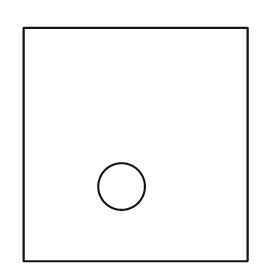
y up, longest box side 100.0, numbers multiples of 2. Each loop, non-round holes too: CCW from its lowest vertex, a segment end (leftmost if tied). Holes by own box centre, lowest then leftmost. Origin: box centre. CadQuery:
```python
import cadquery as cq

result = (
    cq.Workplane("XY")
    .moveTo(-48.0, -50.0)
    .lineTo(48.0, -50.0)
    .lineTo(48.0, 50.0)
    .lineTo(-48.0, 50.0)
    .close()
    .moveTo(-6.0, -18.0)
    .circle(10.0)
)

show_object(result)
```